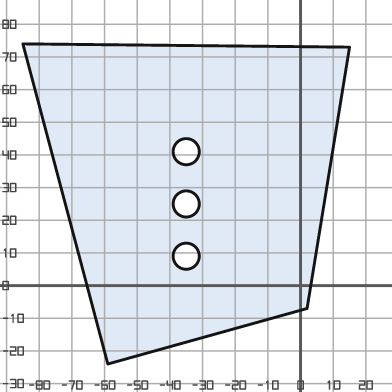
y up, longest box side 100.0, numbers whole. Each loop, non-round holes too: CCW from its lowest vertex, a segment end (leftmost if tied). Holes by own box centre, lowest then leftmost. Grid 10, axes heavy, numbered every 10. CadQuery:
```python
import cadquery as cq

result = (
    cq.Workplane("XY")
    .moveTo(-59.0, -24.0)
    .lineTo(2.0, -7.0)
    .lineTo(15.0, 73.0)
    .lineTo(-85.0, 74.0)
    .close()
    .moveTo(-35.0, 9.0)
    .circle(4.0)
    .moveTo(-35.0, 25.0)
    .circle(4.0)
    .moveTo(-35.0, 41.0)
    .circle(4.0)
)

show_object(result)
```